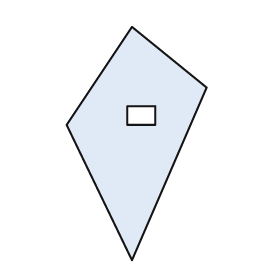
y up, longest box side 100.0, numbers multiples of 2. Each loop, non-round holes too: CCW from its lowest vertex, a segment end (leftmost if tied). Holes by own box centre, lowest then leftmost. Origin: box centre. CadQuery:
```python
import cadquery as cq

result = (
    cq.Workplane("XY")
    .moveTo(-2.0, -50.0)
    .lineTo(30.0, 24.0)
    .lineTo(-2.0, 50.0)
    .lineTo(-30.0, 8.0)
    .close()
    .moveTo(-4.0, 8.0)
    .lineTo(8.0, 8.0)
    .lineTo(8.0, 16.0)
    .lineTo(-4.0, 16.0)
    .close()
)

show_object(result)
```